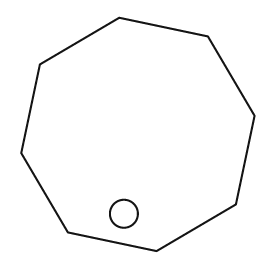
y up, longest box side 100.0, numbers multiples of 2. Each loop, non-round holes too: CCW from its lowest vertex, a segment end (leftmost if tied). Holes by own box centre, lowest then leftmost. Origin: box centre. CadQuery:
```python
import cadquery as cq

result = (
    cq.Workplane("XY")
    .moveTo(8.0, -50.0)
    .lineTo(42.0, -30.0)
    .lineTo(50.0, 8.0)
    .lineTo(30.0, 42.0)
    .lineTo(-8.0, 50.0)
    .lineTo(-42.0, 30.0)
    .lineTo(-50.0, -8.0)
    .lineTo(-30.0, -42.0)
    .close()
    .moveTo(-6.0, -34.0)
    .circle(6.0)
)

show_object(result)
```